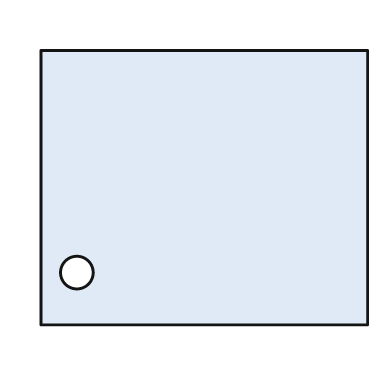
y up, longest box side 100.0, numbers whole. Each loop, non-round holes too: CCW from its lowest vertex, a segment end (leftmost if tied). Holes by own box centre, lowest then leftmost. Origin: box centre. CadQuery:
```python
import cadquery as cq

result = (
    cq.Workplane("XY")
    .moveTo(-50.0, -42.0)
    .lineTo(50.0, -42.0)
    .lineTo(50.0, 42.0)
    .lineTo(-50.0, 42.0)
    .close()
    .moveTo(-39.0, -26.0)
    .circle(5.0)
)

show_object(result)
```